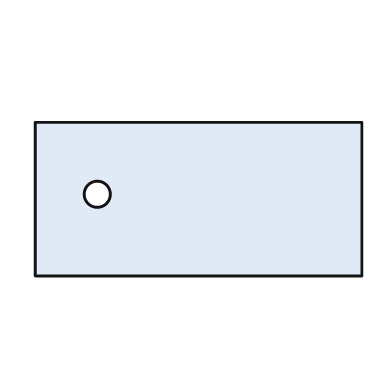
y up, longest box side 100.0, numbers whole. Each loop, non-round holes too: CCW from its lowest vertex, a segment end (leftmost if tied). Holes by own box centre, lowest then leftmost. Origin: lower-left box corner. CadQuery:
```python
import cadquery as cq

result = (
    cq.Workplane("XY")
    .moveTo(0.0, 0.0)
    .lineTo(100.0, 0.0)
    .lineTo(100.0, 47.0)
    .lineTo(0.0, 47.0)
    .close()
    .moveTo(19.0, 25.0)
    .circle(4.0)
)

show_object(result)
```